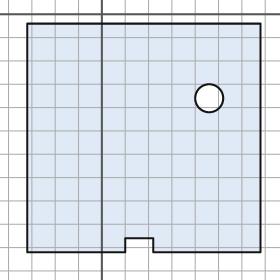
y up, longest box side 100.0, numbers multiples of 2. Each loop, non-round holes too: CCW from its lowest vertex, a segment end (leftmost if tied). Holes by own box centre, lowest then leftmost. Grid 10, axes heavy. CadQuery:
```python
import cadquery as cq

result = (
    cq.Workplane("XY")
    .moveTo(-32.0, -102.0)
    .lineTo(10.0, -102.0)
    .lineTo(10.0, -96.0)
    .lineTo(22.0, -96.0)
    .lineTo(22.0, -102.0)
    .lineTo(68.0, -102.0)
    .lineTo(68.0, -4.0)
    .lineTo(-32.0, -4.0)
    .close()
    .moveTo(46.0, -36.0)
    .circle(6.0)
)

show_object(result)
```